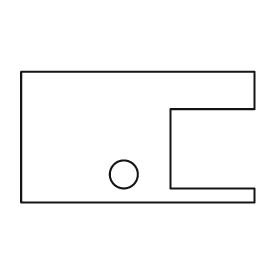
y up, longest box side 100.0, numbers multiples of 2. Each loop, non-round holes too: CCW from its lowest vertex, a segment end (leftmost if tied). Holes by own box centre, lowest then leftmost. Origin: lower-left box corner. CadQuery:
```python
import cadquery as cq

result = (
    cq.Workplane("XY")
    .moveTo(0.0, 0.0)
    .lineTo(100.0, 0.0)
    .lineTo(100.0, 6.0)
    .lineTo(64.0, 6.0)
    .lineTo(64.0, 40.0)
    .lineTo(100.0, 40.0)
    .lineTo(100.0, 56.0)
    .lineTo(0.0, 56.0)
    .close()
    .moveTo(44.0, 12.0)
    .circle(6.0)
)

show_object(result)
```